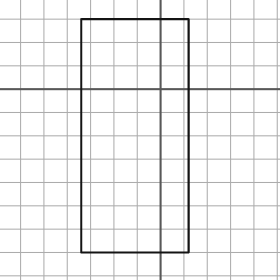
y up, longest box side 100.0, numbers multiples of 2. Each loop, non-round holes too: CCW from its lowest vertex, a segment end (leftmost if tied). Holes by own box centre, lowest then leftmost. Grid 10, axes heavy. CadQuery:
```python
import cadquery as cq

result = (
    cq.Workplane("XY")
    .moveTo(-34.0, -70.0)
    .lineTo(12.0, -70.0)
    .lineTo(12.0, 30.0)
    .lineTo(-34.0, 30.0)
    .close()
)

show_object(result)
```